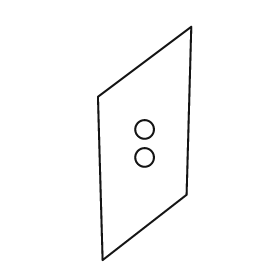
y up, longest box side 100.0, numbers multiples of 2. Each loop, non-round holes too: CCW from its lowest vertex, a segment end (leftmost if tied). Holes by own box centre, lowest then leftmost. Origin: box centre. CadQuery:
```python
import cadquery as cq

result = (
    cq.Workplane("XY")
    .moveTo(-18.0, -50.0)
    .lineTo(18.0, -22.0)
    .lineTo(20.0, 50.0)
    .lineTo(-20.0, 20.0)
    .close()
    .moveTo(0.0, -6.0)
    .circle(4.0)
    .moveTo(0.0, 6.0)
    .circle(4.0)
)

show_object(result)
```